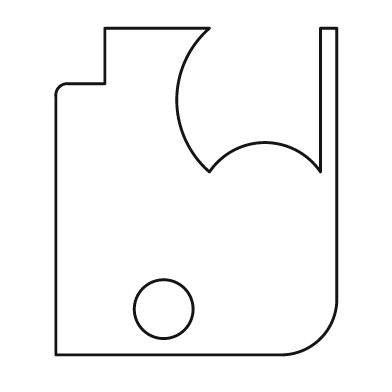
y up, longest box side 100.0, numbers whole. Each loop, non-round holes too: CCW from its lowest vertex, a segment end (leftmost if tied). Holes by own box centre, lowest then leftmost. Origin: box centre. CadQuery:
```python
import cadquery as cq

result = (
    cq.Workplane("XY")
    .moveTo(-43.0, -50.0)
    .lineTo(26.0, -50.0)
    .threePointArc((38.0, -45.0), (43.0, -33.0))
    .lineTo(43.0, 50.0)
    .lineTo(38.0, 50.0)
    .lineTo(38.0, 6.0)
    .threePointArc((21.0, 15.0), (4.0, 6.0))
    .threePointArc((-6.0, 28.0), (4.0, 50.0))
    .lineTo(-28.0, 50.0)
    .lineTo(-28.0, 33.0)
    .lineTo(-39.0, 33.0)
    .threePointArc((-42.0, 32.0), (-43.0, 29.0))
    .close()
    .moveTo(-10.0, -36.0)
    .circle(9.0)
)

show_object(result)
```